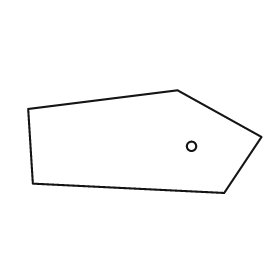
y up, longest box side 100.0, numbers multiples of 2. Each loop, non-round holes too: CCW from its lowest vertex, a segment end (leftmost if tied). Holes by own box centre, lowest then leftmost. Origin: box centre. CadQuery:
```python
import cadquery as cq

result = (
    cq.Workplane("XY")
    .moveTo(34.0, -22.0)
    .lineTo(50.0, 2.0)
    .lineTo(14.0, 22.0)
    .lineTo(-50.0, 14.0)
    .lineTo(-48.0, -18.0)
    .close()
    .moveTo(20.0, -2.0)
    .circle(2.0)
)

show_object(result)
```